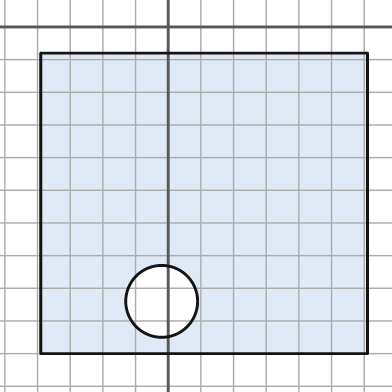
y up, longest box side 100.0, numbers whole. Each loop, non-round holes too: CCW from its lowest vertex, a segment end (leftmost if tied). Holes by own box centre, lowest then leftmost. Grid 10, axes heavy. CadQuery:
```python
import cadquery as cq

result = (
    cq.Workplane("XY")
    .moveTo(-39.0, -100.0)
    .lineTo(61.0, -100.0)
    .lineTo(61.0, -8.0)
    .lineTo(-39.0, -8.0)
    .close()
    .moveTo(-2.0, -84.0)
    .circle(11.0)
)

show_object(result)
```